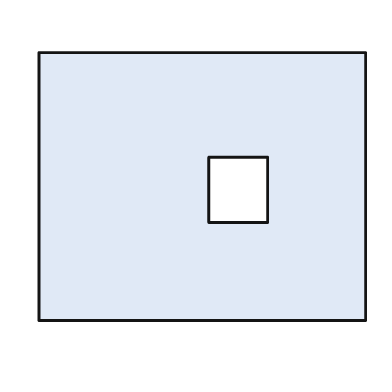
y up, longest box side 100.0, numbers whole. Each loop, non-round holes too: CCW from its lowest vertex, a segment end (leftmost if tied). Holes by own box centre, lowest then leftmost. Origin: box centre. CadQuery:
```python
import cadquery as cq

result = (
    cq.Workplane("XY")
    .moveTo(-50.0, -41.0)
    .lineTo(50.0, -41.0)
    .lineTo(50.0, 41.0)
    .lineTo(-50.0, 41.0)
    .close()
    .moveTo(2.0, -11.0)
    .lineTo(20.0, -11.0)
    .lineTo(20.0, 9.0)
    .lineTo(2.0, 9.0)
    .close()
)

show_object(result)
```